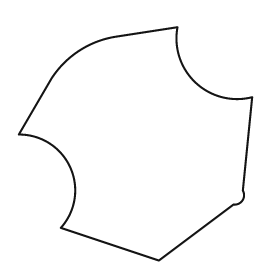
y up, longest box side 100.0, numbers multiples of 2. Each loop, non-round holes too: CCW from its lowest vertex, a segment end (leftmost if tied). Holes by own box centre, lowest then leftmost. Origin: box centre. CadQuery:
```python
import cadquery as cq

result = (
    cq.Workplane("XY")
    .moveTo(10.0, -50.0)
    .lineTo(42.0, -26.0)
    .threePointArc((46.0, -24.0), (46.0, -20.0))
    .lineTo(50.0, 20.0)
    .threePointArc((26.0, 26.0), (18.0, 50.0))
    .lineTo(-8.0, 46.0)
    .threePointArc((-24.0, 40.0), (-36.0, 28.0))
    .lineTo(-50.0, 4.0)
    .threePointArc((-28.0, -10.0), (-32.0, -36.0))
    .close()
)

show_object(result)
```